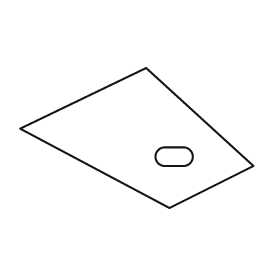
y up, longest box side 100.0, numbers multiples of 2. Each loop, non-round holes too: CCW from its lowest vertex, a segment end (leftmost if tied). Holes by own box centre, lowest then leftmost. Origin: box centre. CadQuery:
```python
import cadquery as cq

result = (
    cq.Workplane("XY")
    .moveTo(14.0, -30.0)
    .lineTo(50.0, -12.0)
    .lineTo(4.0, 30.0)
    .lineTo(-50.0, 4.0)
    .close()
    .moveTo(12.0, -12.0)
    .lineTo(20.0, -12.0)
    .threePointArc((24.0, -8.0), (20.0, -4.0))
    .lineTo(12.0, -4.0)
    .threePointArc((8.0, -8.0), (12.0, -12.0))
    .close()
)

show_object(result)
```